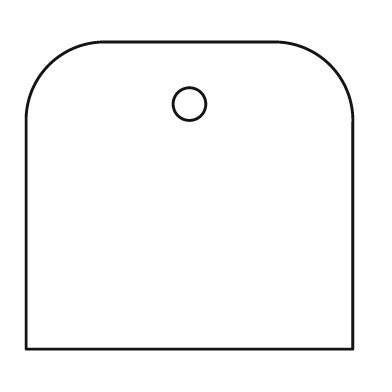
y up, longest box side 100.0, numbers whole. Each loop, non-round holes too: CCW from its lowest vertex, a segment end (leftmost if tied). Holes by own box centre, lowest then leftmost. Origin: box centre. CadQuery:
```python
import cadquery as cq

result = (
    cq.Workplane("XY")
    .moveTo(-50.0, -47.0)
    .lineTo(50.0, -47.0)
    .lineTo(50.0, 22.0)
    .threePointArc((43.0, 40.0), (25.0, 47.0))
    .lineTo(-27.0, 47.0)
    .threePointArc((-43.0, 40.0), (-50.0, 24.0))
    .close()
    .moveTo(0.0, 28.0)
    .circle(5.0)
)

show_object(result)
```